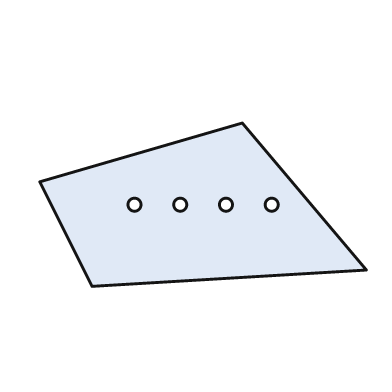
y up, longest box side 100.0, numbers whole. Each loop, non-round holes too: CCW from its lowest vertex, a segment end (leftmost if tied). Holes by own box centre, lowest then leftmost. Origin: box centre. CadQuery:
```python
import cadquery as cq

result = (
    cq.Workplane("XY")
    .moveTo(-34.0, -25.0)
    .lineTo(50.0, -20.0)
    .lineTo(12.0, 25.0)
    .lineTo(-50.0, 7.0)
    .close()
    .moveTo(-21.0, 0.0)
    .circle(2.0)
    .moveTo(-7.0, 0.0)
    .circle(2.0)
    .moveTo(7.0, 0.0)
    .circle(2.0)
    .moveTo(21.0, 0.0)
    .circle(2.0)
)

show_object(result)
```